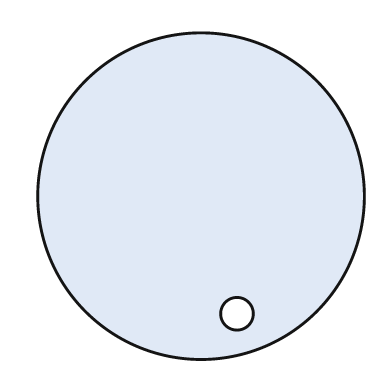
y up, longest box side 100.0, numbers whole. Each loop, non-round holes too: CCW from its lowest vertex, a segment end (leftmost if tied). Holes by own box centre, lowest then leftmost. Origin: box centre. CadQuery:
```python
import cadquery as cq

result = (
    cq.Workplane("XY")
    .moveTo(0.0, 0.0)
    .circle(50.0)
    .moveTo(11.0, -36.0)
    .circle(5.0)
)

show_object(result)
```